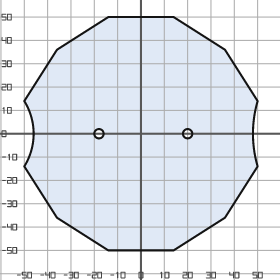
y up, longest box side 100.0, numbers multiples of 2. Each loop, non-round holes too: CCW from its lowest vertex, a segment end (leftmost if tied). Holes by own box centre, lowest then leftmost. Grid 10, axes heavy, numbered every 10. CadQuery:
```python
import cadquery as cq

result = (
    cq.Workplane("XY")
    .moveTo(-14.0, -50.0)
    .lineTo(14.0, -50.0)
    .lineTo(36.0, -36.0)
    .lineTo(50.0, -14.0)
    .threePointArc((48.0, 0.0), (50.0, 14.0))
    .lineTo(36.0, 36.0)
    .lineTo(14.0, 50.0)
    .lineTo(-14.0, 50.0)
    .lineTo(-36.0, 36.0)
    .lineTo(-50.0, 14.0)
    .threePointArc((-46.0, 0.0), (-50.0, -14.0))
    .lineTo(-36.0, -36.0)
    .close()
    .moveTo(-18.0, 0.0)
    .circle(2.0)
    .moveTo(20.0, 0.0)
    .circle(2.0)
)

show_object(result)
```